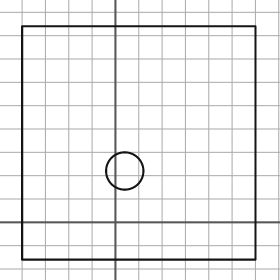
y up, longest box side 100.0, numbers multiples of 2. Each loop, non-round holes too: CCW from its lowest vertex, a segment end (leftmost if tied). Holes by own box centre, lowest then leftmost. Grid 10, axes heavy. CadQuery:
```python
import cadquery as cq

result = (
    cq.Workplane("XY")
    .moveTo(-40.0, -16.0)
    .lineTo(60.0, -16.0)
    .lineTo(60.0, 84.0)
    .lineTo(-40.0, 84.0)
    .close()
    .moveTo(4.0, 22.0)
    .circle(8.0)
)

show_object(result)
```